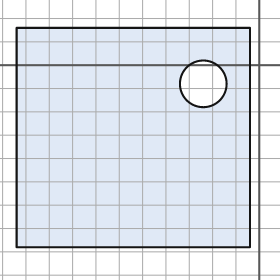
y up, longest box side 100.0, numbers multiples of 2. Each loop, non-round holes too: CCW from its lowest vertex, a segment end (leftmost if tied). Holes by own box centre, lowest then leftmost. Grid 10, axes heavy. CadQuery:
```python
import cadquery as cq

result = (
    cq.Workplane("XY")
    .moveTo(-104.0, -78.0)
    .lineTo(-4.0, -78.0)
    .lineTo(-4.0, 16.0)
    .lineTo(-104.0, 16.0)
    .close()
    .moveTo(-24.0, -8.0)
    .circle(10.0)
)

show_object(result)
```